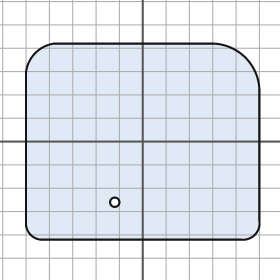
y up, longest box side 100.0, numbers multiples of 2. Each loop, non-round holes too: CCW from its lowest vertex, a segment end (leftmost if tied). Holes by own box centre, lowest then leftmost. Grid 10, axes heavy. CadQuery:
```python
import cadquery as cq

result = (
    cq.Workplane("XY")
    .moveTo(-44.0, -42.0)
    .lineTo(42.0, -42.0)
    .threePointArc((48.0, -40.0), (50.0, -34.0))
    .lineTo(50.0, 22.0)
    .threePointArc((44.0, 36.0), (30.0, 42.0))
    .lineTo(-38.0, 42.0)
    .threePointArc((-46.0, 38.0), (-50.0, 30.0))
    .lineTo(-50.0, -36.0)
    .threePointArc((-48.0, -40.0), (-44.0, -42.0))
    .close()
    .moveTo(-12.0, -26.0)
    .circle(2.0)
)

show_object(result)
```